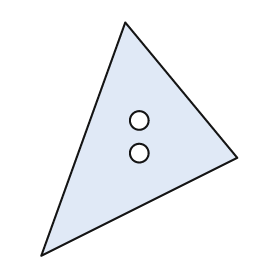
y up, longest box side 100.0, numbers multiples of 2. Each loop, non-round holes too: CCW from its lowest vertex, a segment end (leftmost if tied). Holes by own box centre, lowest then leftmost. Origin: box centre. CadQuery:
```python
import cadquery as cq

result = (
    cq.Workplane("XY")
    .moveTo(-42.0, -50.0)
    .lineTo(42.0, -8.0)
    .lineTo(-6.0, 50.0)
    .close()
    .moveTo(0.0, -6.0)
    .circle(4.0)
    .moveTo(0.0, 8.0)
    .circle(4.0)
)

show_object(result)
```